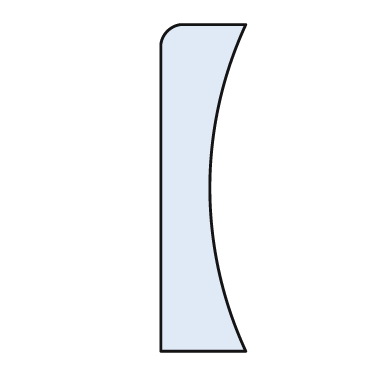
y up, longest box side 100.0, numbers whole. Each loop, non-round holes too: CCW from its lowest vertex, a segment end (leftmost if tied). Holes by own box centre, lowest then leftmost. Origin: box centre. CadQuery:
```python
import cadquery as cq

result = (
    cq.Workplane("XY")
    .moveTo(-13.0, -50.0)
    .lineTo(13.0, -50.0)
    .threePointArc((2.0, 0.0), (13.0, 50.0))
    .lineTo(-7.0, 50.0)
    .threePointArc((-11.0, 48.0), (-13.0, 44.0))
    .close()
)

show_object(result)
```